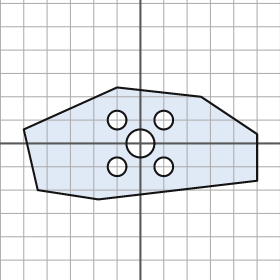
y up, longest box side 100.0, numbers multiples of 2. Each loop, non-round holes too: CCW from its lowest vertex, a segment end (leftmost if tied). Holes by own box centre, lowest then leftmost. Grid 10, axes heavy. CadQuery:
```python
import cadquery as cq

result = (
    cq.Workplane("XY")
    .moveTo(-18.0, -24.0)
    .lineTo(50.0, -16.0)
    .lineTo(50.0, 4.0)
    .lineTo(26.0, 20.0)
    .lineTo(-10.0, 24.0)
    .lineTo(-50.0, 6.0)
    .lineTo(-44.0, -20.0)
    .close()
    .moveTo(-10.0, -10.0)
    .circle(4.0)
    .moveTo(10.0, -10.0)
    .circle(4.0)
    .moveTo(0.0, 0.0)
    .circle(6.0)
    .moveTo(-10.0, 10.0)
    .circle(4.0)
    .moveTo(10.0, 10.0)
    .circle(4.0)
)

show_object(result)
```